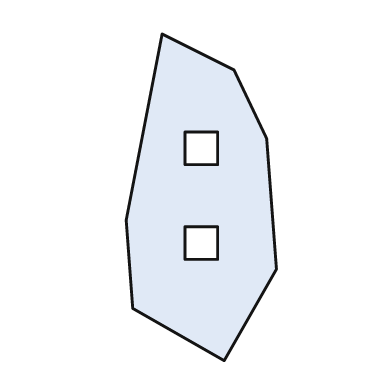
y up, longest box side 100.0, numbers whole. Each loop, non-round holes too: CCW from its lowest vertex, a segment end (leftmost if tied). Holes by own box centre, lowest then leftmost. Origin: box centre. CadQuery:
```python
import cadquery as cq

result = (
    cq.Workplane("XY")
    .moveTo(7.0, -50.0)
    .lineTo(23.0, -22.0)
    .lineTo(20.0, 18.0)
    .lineTo(10.0, 39.0)
    .lineTo(-12.0, 50.0)
    .lineTo(-23.0, -7.0)
    .lineTo(-21.0, -34.0)
    .close()
    .moveTo(-5.0, -19.0)
    .lineTo(5.0, -19.0)
    .lineTo(5.0, -9.0)
    .lineTo(-5.0, -9.0)
    .close()
    .moveTo(-5.0, 10.0)
    .lineTo(5.0, 10.0)
    .lineTo(5.0, 20.0)
    .lineTo(-5.0, 20.0)
    .close()
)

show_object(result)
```